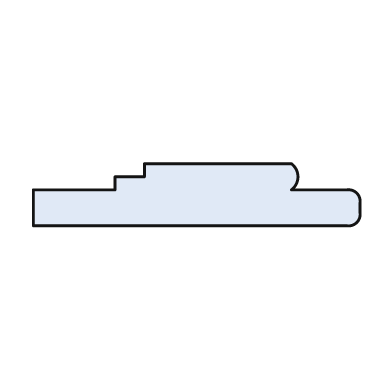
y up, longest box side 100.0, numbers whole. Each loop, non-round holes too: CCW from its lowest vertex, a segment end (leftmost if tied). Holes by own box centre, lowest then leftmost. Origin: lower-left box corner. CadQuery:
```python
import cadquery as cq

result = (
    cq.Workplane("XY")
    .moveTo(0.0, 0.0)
    .lineTo(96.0, 0.0)
    .threePointArc((99.0, 1.0), (100.0, 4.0))
    .lineTo(100.0, 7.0)
    .threePointArc((99.0, 10.0), (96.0, 11.0))
    .lineTo(79.0, 11.0)
    .threePointArc((81.0, 15.0), (79.0, 19.0))
    .lineTo(34.0, 19.0)
    .lineTo(34.0, 15.0)
    .lineTo(25.0, 15.0)
    .lineTo(25.0, 11.0)
    .lineTo(0.0, 11.0)
    .close()
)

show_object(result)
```